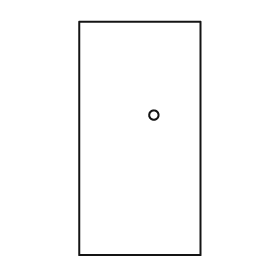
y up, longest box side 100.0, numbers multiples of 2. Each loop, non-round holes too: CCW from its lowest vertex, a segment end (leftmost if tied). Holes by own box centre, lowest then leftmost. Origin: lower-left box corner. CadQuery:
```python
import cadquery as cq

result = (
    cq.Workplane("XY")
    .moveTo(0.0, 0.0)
    .lineTo(52.0, 0.0)
    .lineTo(52.0, 100.0)
    .lineTo(0.0, 100.0)
    .close()
    .moveTo(32.0, 60.0)
    .circle(2.0)
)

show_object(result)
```